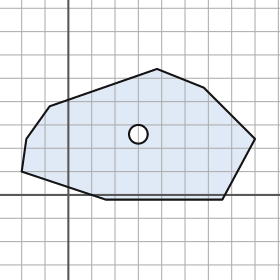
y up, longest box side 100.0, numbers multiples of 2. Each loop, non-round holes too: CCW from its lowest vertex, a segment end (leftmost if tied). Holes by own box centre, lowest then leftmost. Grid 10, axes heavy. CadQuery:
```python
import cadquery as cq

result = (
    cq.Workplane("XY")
    .moveTo(16.0, -2.0)
    .lineTo(66.0, -2.0)
    .lineTo(80.0, 24.0)
    .lineTo(58.0, 46.0)
    .lineTo(38.0, 54.0)
    .lineTo(-8.0, 38.0)
    .lineTo(-18.0, 24.0)
    .lineTo(-20.0, 10.0)
    .close()
    .moveTo(30.0, 26.0)
    .circle(4.0)
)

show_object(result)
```